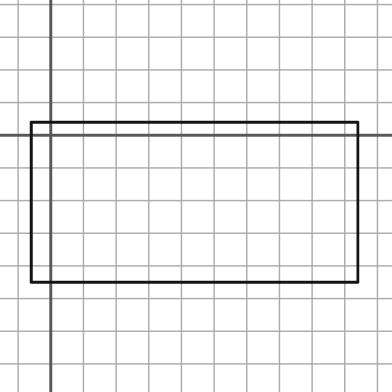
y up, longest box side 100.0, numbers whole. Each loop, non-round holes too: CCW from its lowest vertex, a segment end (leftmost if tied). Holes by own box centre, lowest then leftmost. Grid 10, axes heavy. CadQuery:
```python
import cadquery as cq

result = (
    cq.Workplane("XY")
    .moveTo(-6.0, -45.0)
    .lineTo(94.0, -45.0)
    .lineTo(94.0, 4.0)
    .lineTo(-6.0, 4.0)
    .close()
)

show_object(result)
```